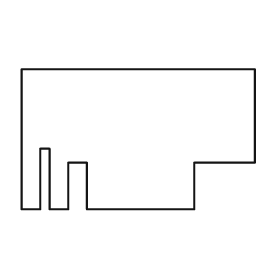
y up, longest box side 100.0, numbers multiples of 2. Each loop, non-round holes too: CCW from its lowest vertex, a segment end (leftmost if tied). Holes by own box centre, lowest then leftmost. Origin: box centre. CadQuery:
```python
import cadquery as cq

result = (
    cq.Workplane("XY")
    .moveTo(-50.0, -30.0)
    .lineTo(-42.0, -30.0)
    .lineTo(-42.0, -4.0)
    .lineTo(-38.0, -4.0)
    .lineTo(-38.0, -30.0)
    .lineTo(-30.0, -30.0)
    .lineTo(-30.0, -10.0)
    .lineTo(-22.0, -10.0)
    .lineTo(-22.0, -30.0)
    .lineTo(24.0, -30.0)
    .lineTo(24.0, -10.0)
    .lineTo(50.0, -10.0)
    .lineTo(50.0, 30.0)
    .lineTo(-50.0, 30.0)
    .close()
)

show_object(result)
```